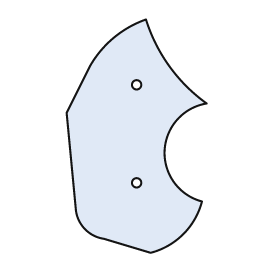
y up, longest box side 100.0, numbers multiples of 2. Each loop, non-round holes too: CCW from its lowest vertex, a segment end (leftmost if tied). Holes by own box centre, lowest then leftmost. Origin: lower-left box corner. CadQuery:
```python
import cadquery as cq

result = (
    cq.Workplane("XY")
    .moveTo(36.0, 0.0)
    .threePointArc((50.0, 8.0), (58.0, 22.0))
    .threePointArc((42.0, 44.0), (60.0, 64.0))
    .threePointArc((44.0, 80.0), (34.0, 100.0))
    .threePointArc((20.0, 92.0), (10.0, 80.0))
    .lineTo(0.0, 60.0)
    .lineTo(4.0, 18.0)
    .threePointArc((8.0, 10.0), (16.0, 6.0))
    .close()
    .moveTo(30.0, 30.0)
    .circle(2.0)
    .moveTo(30.0, 72.0)
    .circle(2.0)
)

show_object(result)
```